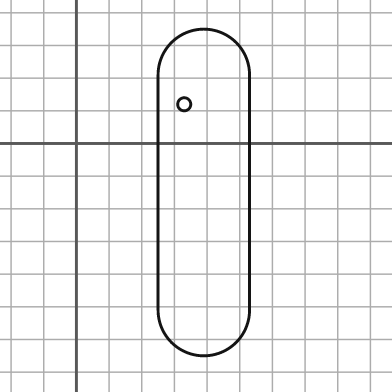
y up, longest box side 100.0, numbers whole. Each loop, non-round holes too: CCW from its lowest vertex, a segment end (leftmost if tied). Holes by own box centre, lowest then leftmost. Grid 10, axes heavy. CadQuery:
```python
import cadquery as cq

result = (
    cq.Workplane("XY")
    .moveTo(25.0, -51.0)
    .threePointArc((39.0, -65.0), (53.0, -51.0))
    .lineTo(53.0, 21.0)
    .threePointArc((39.0, 35.0), (25.0, 21.0))
    .close()
    .moveTo(33.0, 12.0)
    .circle(2.0)
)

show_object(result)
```